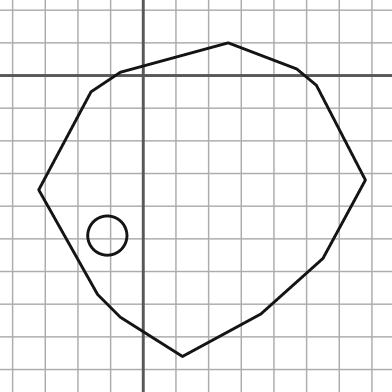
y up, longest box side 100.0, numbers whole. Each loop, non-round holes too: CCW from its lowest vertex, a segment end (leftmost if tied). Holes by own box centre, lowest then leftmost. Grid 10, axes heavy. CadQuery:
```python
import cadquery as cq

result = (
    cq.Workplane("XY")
    .moveTo(12.0, -86.0)
    .lineTo(36.0, -73.0)
    .lineTo(55.0, -56.0)
    .lineTo(68.0, -32.0)
    .lineTo(53.0, -3.0)
    .lineTo(47.0, 2.0)
    .lineTo(26.0, 10.0)
    .lineTo(-7.0, 1.0)
    .lineTo(-16.0, -5.0)
    .lineTo(-32.0, -35.0)
    .lineTo(-14.0, -67.0)
    .lineTo(-7.0, -74.0)
    .close()
    .moveTo(-11.0, -49.0)
    .circle(6.0)
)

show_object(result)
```